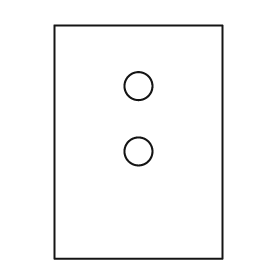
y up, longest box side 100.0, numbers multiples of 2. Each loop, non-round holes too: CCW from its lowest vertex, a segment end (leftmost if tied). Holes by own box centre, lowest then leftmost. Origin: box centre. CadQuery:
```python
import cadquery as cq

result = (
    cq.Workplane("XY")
    .moveTo(-36.0, -50.0)
    .lineTo(36.0, -50.0)
    .lineTo(36.0, 50.0)
    .lineTo(-36.0, 50.0)
    .close()
    .moveTo(0.0, -4.0)
    .circle(6.0)
    .moveTo(0.0, 24.0)
    .circle(6.0)
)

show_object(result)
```